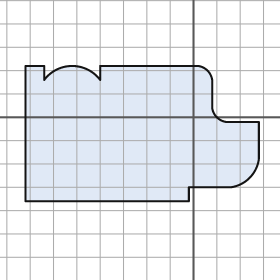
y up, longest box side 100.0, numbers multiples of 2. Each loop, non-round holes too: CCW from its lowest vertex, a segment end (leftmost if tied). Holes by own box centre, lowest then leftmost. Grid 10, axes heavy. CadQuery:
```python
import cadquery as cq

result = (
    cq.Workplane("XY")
    .moveTo(-72.0, -36.0)
    .lineTo(-2.0, -36.0)
    .lineTo(-2.0, -30.0)
    .lineTo(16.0, -30.0)
    .threePointArc((24.0, -26.0), (28.0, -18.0))
    .lineTo(28.0, -2.0)
    .lineTo(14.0, -2.0)
    .threePointArc((10.0, 0.0), (8.0, 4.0))
    .lineTo(8.0, 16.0)
    .threePointArc((6.0, 20.0), (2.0, 22.0))
    .lineTo(-40.0, 22.0)
    .lineTo(-40.0, 16.0)
    .threePointArc((-52.0, 22.0), (-64.0, 16.0))
    .lineTo(-64.0, 22.0)
    .lineTo(-72.0, 22.0)
    .close()
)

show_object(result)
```